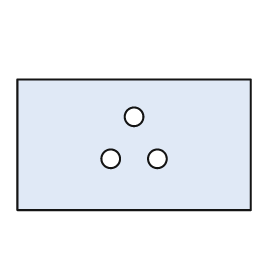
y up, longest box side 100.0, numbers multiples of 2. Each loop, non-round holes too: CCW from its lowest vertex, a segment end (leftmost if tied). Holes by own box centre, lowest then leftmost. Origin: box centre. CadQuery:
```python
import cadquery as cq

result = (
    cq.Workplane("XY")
    .moveTo(-50.0, -28.0)
    .lineTo(50.0, -28.0)
    .lineTo(50.0, 28.0)
    .lineTo(-50.0, 28.0)
    .close()
    .moveTo(-10.0, -6.0)
    .circle(4.0)
    .moveTo(10.0, -6.0)
    .circle(4.0)
    .moveTo(0.0, 12.0)
    .circle(4.0)
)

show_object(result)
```